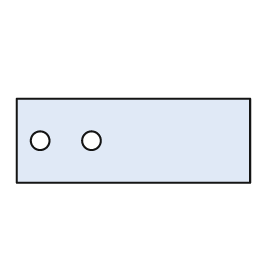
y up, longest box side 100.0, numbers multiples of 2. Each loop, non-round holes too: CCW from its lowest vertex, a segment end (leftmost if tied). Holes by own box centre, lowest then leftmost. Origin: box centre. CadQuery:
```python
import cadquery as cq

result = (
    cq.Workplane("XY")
    .moveTo(-50.0, -18.0)
    .lineTo(50.0, -18.0)
    .lineTo(50.0, 18.0)
    .lineTo(-50.0, 18.0)
    .close()
    .moveTo(-40.0, 0.0)
    .circle(4.0)
    .moveTo(-18.0, 0.0)
    .circle(4.0)
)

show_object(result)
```